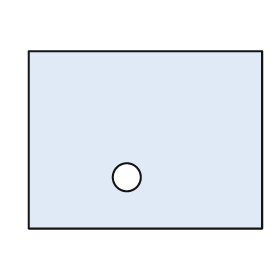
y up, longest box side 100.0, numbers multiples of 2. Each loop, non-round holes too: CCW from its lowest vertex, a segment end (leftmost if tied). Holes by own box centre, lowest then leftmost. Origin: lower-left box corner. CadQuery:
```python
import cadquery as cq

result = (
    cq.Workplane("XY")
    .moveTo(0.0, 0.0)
    .lineTo(100.0, 0.0)
    .lineTo(100.0, 76.0)
    .lineTo(0.0, 76.0)
    .close()
    .moveTo(42.0, 22.0)
    .circle(6.0)
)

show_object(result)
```